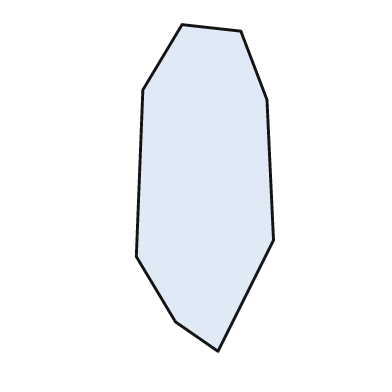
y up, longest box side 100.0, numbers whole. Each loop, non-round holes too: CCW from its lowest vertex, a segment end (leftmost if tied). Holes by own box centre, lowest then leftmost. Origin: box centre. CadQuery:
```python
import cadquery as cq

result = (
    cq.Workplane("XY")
    .moveTo(4.0, -50.0)
    .lineTo(21.0, -16.0)
    .lineTo(19.0, 27.0)
    .lineTo(11.0, 48.0)
    .lineTo(-7.0, 50.0)
    .lineTo(-19.0, 30.0)
    .lineTo(-21.0, -21.0)
    .lineTo(-9.0, -41.0)
    .close()
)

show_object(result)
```